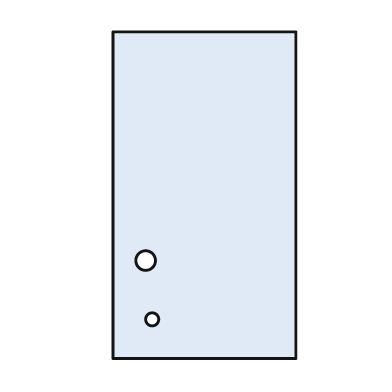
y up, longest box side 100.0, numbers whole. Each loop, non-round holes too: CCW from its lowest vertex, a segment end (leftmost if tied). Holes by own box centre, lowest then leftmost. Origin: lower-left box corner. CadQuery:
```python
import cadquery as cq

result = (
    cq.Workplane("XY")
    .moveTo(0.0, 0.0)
    .lineTo(56.0, 0.0)
    .lineTo(56.0, 100.0)
    .lineTo(0.0, 100.0)
    .close()
    .moveTo(12.0, 12.0)
    .circle(2.0)
    .moveTo(10.0, 30.0)
    .circle(3.0)
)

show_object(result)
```